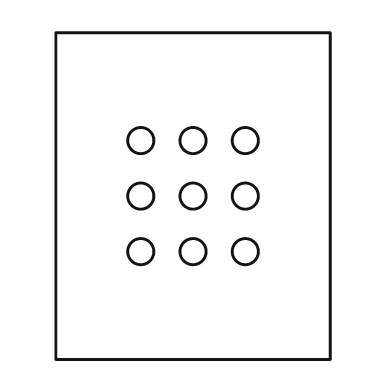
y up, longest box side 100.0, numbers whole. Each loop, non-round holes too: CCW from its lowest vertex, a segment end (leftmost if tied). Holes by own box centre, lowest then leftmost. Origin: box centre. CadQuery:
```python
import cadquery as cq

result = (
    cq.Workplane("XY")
    .moveTo(-42.0, -50.0)
    .lineTo(42.0, -50.0)
    .lineTo(42.0, 50.0)
    .lineTo(-42.0, 50.0)
    .close()
    .moveTo(-16.0, -17.0)
    .circle(4.0)
    .moveTo(0.0, -17.0)
    .circle(4.0)
    .moveTo(16.0, -17.0)
    .circle(4.0)
    .moveTo(-16.0, 0.0)
    .circle(4.0)
    .moveTo(0.0, 0.0)
    .circle(4.0)
    .moveTo(16.0, 0.0)
    .circle(4.0)
    .moveTo(-16.0, 17.0)
    .circle(4.0)
    .moveTo(0.0, 17.0)
    .circle(4.0)
    .moveTo(16.0, 17.0)
    .circle(4.0)
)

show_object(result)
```